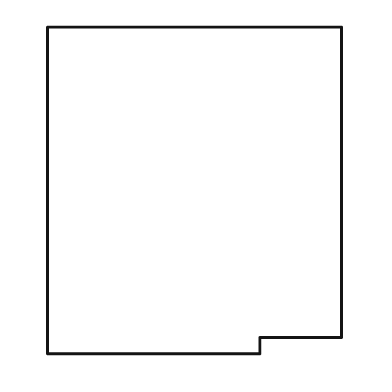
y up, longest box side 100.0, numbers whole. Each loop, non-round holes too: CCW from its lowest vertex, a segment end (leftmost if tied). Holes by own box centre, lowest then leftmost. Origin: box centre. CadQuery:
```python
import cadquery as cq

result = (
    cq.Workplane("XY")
    .moveTo(-45.0, -50.0)
    .lineTo(20.0, -50.0)
    .lineTo(20.0, -45.0)
    .lineTo(45.0, -45.0)
    .lineTo(45.0, 50.0)
    .lineTo(-45.0, 50.0)
    .close()
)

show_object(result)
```